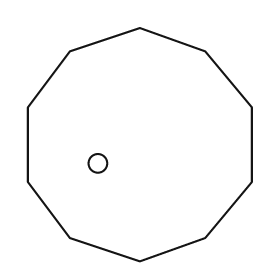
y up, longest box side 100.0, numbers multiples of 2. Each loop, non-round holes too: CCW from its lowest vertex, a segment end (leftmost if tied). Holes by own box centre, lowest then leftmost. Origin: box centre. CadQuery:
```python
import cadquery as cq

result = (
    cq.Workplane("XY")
    .moveTo(0.0, -50.0)
    .lineTo(28.0, -40.0)
    .lineTo(48.0, -16.0)
    .lineTo(48.0, 16.0)
    .lineTo(28.0, 40.0)
    .lineTo(0.0, 50.0)
    .lineTo(-30.0, 40.0)
    .lineTo(-48.0, 16.0)
    .lineTo(-48.0, -16.0)
    .lineTo(-30.0, -40.0)
    .close()
    .moveTo(-18.0, -8.0)
    .circle(4.0)
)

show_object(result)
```